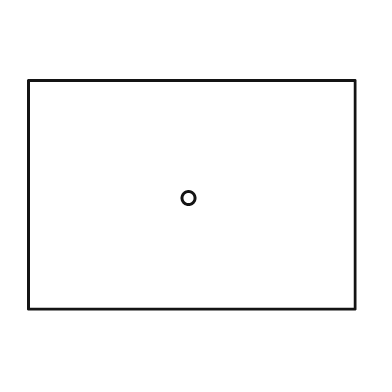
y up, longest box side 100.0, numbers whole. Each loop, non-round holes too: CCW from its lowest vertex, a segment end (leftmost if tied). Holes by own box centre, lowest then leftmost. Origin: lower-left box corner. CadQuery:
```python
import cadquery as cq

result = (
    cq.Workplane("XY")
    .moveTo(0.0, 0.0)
    .lineTo(100.0, 0.0)
    .lineTo(100.0, 70.0)
    .lineTo(0.0, 70.0)
    .close()
    .moveTo(49.0, 34.0)
    .circle(2.0)
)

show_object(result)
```